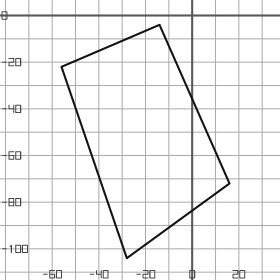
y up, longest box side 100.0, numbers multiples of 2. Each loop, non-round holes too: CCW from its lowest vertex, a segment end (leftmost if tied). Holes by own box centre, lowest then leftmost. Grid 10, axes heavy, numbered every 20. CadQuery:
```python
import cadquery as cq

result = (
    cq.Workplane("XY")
    .moveTo(-28.0, -104.0)
    .lineTo(16.0, -72.0)
    .lineTo(-14.0, -4.0)
    .lineTo(-56.0, -22.0)
    .close()
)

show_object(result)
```